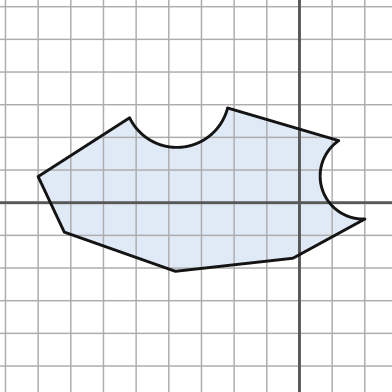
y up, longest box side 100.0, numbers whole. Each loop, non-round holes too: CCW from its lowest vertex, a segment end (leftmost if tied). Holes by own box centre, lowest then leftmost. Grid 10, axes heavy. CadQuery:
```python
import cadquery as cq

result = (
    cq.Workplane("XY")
    .moveTo(-38.0, -21.0)
    .lineTo(-2.0, -17.0)
    .lineTo(20.0, -5.0)
    .threePointArc((7.0, 4.0), (12.0, 19.0))
    .lineTo(-22.0, 29.0)
    .threePointArc((-36.0, 17.0), (-52.0, 26.0))
    .lineTo(-80.0, 8.0)
    .lineTo(-72.0, -9.0)
    .close()
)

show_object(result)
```